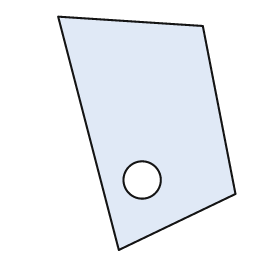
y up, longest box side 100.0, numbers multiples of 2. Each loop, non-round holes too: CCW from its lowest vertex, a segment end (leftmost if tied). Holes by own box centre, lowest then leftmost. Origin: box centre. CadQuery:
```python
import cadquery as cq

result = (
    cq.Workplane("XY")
    .moveTo(-12.0, -50.0)
    .lineTo(38.0, -26.0)
    .lineTo(24.0, 46.0)
    .lineTo(-38.0, 50.0)
    .close()
    .moveTo(-2.0, -20.0)
    .circle(8.0)
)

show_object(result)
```